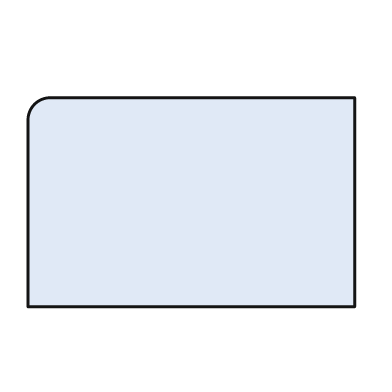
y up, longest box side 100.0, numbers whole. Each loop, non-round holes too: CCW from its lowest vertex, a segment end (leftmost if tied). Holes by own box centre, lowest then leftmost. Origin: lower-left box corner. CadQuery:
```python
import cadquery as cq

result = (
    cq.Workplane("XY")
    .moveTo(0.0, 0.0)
    .lineTo(100.0, 0.0)
    .lineTo(100.0, 64.0)
    .lineTo(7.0, 64.0)
    .threePointArc((2.0, 62.0), (0.0, 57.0))
    .close()
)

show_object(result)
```